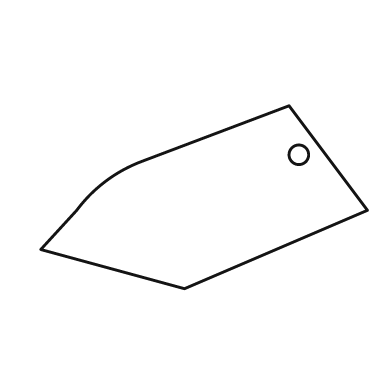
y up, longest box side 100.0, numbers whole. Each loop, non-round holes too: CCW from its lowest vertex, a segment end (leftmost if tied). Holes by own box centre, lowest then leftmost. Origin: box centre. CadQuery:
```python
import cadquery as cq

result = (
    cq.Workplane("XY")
    .moveTo(-6.0, -28.0)
    .lineTo(50.0, -4.0)
    .lineTo(26.0, 28.0)
    .lineTo(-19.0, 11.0)
    .threePointArc((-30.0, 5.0), (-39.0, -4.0))
    .lineTo(-50.0, -16.0)
    .close()
    .moveTo(29.0, 13.0)
    .circle(3.0)
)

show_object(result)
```